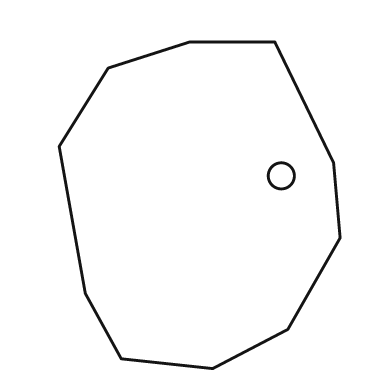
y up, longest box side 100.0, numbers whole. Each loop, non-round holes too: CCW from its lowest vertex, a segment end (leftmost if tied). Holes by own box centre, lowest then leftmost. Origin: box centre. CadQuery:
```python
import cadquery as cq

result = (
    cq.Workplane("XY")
    .moveTo(4.0, -50.0)
    .lineTo(27.0, -38.0)
    .lineTo(43.0, -10.0)
    .lineTo(41.0, 13.0)
    .lineTo(23.0, 50.0)
    .lineTo(-3.0, 50.0)
    .lineTo(-28.0, 42.0)
    .lineTo(-43.0, 18.0)
    .lineTo(-35.0, -27.0)
    .lineTo(-24.0, -47.0)
    .close()
    .moveTo(25.0, 9.0)
    .circle(4.0)
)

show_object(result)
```